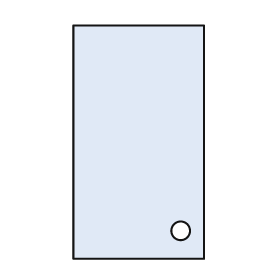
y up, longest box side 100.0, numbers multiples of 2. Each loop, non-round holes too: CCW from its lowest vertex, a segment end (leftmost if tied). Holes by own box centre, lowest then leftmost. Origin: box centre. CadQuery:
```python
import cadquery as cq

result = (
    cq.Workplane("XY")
    .moveTo(-28.0, -50.0)
    .lineTo(28.0, -50.0)
    .lineTo(28.0, 50.0)
    .lineTo(-28.0, 50.0)
    .close()
    .moveTo(18.0, -38.0)
    .circle(4.0)
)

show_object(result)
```